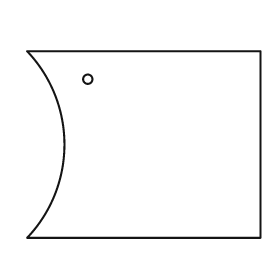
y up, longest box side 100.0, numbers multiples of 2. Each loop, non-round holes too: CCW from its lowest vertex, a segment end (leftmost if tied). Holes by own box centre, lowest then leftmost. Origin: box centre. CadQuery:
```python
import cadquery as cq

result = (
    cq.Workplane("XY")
    .moveTo(-50.0, -40.0)
    .lineTo(50.0, -40.0)
    .lineTo(50.0, 40.0)
    .lineTo(-50.0, 40.0)
    .threePointArc((-34.0, 0.0), (-50.0, -40.0))
    .close()
    .moveTo(-24.0, 28.0)
    .circle(2.0)
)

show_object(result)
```